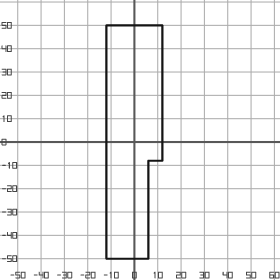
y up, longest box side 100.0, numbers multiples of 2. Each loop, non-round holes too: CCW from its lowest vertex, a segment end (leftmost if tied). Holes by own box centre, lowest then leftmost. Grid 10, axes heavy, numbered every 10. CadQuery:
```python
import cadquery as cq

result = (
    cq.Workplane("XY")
    .moveTo(-12.0, -50.0)
    .lineTo(6.0, -50.0)
    .lineTo(6.0, -8.0)
    .lineTo(12.0, -8.0)
    .lineTo(12.0, 50.0)
    .lineTo(-12.0, 50.0)
    .close()
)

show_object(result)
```